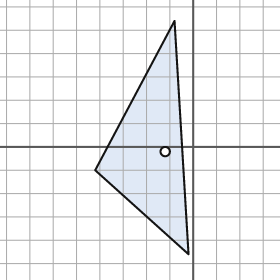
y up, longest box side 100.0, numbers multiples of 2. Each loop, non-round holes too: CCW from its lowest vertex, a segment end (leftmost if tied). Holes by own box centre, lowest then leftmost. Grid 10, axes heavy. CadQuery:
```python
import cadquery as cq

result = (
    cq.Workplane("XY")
    .moveTo(-2.0, -46.0)
    .lineTo(-8.0, 54.0)
    .lineTo(-42.0, -10.0)
    .close()
    .moveTo(-12.0, -2.0)
    .circle(2.0)
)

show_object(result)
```